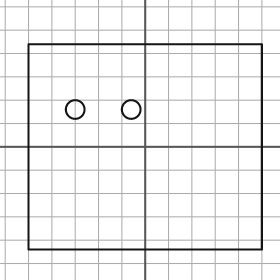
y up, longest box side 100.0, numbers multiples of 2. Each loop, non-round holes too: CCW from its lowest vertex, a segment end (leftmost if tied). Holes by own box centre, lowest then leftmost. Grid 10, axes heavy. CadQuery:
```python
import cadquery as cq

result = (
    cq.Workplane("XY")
    .moveTo(-50.0, -44.0)
    .lineTo(50.0, -44.0)
    .lineTo(50.0, 44.0)
    .lineTo(-50.0, 44.0)
    .close()
    .moveTo(-30.0, 16.0)
    .circle(4.0)
    .moveTo(-6.0, 16.0)
    .circle(4.0)
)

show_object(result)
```